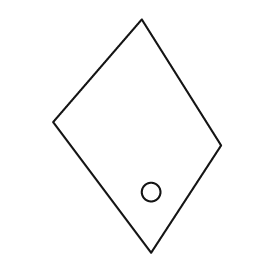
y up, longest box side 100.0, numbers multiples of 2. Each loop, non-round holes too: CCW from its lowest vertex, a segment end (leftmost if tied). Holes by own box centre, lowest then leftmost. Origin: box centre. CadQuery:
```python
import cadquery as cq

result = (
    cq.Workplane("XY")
    .moveTo(6.0, -50.0)
    .lineTo(36.0, -4.0)
    .lineTo(2.0, 50.0)
    .lineTo(-36.0, 6.0)
    .close()
    .moveTo(6.0, -24.0)
    .circle(4.0)
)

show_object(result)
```